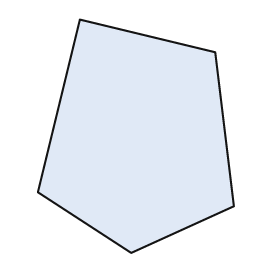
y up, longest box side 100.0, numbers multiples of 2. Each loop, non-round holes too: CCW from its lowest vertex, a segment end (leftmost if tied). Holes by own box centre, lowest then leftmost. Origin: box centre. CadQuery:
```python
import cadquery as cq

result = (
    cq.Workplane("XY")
    .moveTo(-2.0, -50.0)
    .lineTo(42.0, -30.0)
    .lineTo(34.0, 36.0)
    .lineTo(-24.0, 50.0)
    .lineTo(-42.0, -24.0)
    .close()
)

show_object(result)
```